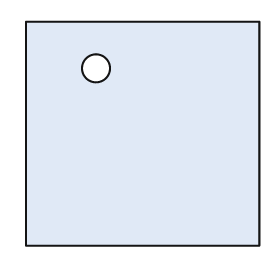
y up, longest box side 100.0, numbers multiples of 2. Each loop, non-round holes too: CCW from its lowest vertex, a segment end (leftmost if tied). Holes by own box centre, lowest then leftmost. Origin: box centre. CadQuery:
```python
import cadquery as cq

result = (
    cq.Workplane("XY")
    .moveTo(-50.0, -48.0)
    .lineTo(50.0, -48.0)
    .lineTo(50.0, 48.0)
    .lineTo(-50.0, 48.0)
    .close()
    .moveTo(-20.0, 28.0)
    .circle(6.0)
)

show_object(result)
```